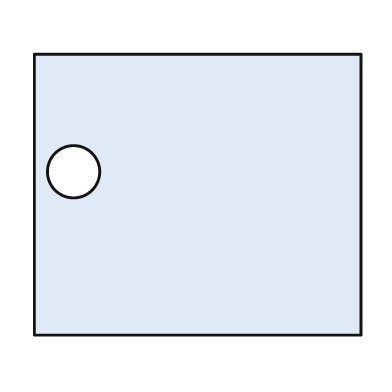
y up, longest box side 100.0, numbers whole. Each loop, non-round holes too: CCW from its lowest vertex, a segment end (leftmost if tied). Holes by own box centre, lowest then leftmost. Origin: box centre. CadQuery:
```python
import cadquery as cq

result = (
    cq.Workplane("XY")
    .moveTo(-50.0, -43.0)
    .lineTo(50.0, -43.0)
    .lineTo(50.0, 43.0)
    .lineTo(-50.0, 43.0)
    .close()
    .moveTo(-38.0, 7.0)
    .circle(8.0)
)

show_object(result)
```